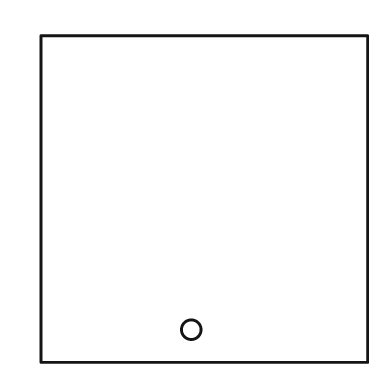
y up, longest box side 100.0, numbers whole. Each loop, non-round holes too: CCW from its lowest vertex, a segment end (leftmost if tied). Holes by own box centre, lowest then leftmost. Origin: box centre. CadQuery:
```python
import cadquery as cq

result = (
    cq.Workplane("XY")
    .moveTo(-50.0, -50.0)
    .lineTo(50.0, -50.0)
    .lineTo(50.0, 50.0)
    .lineTo(-50.0, 50.0)
    .close()
    .moveTo(-4.0, -40.0)
    .circle(3.0)
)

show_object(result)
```